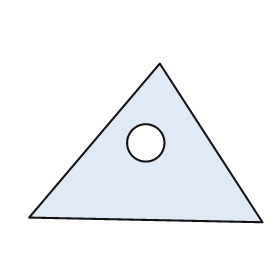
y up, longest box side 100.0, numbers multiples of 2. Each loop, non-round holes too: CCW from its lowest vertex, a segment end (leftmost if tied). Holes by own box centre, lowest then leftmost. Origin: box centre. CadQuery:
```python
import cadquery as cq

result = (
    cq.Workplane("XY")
    .moveTo(50.0, -34.0)
    .lineTo(6.0, 34.0)
    .lineTo(-50.0, -32.0)
    .close()
    .moveTo(0.0, 0.0)
    .circle(8.0)
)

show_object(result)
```